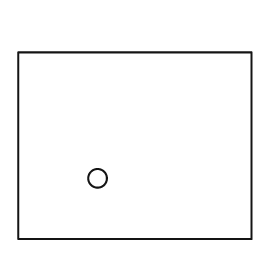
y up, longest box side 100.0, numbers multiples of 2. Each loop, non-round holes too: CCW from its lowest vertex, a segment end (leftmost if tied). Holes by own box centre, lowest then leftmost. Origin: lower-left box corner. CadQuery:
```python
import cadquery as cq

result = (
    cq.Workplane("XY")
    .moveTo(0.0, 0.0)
    .lineTo(100.0, 0.0)
    .lineTo(100.0, 80.0)
    .lineTo(0.0, 80.0)
    .close()
    .moveTo(34.0, 26.0)
    .circle(4.0)
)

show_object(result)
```